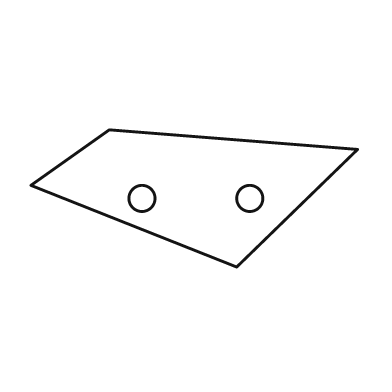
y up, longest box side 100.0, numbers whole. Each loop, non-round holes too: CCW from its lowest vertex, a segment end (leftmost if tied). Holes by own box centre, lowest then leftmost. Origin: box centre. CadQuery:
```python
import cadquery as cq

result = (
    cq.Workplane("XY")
    .moveTo(13.0, -21.0)
    .lineTo(50.0, 15.0)
    .lineTo(-26.0, 21.0)
    .lineTo(-50.0, 4.0)
    .close()
    .moveTo(-16.0, 0.0)
    .circle(4.0)
    .moveTo(17.0, 0.0)
    .circle(4.0)
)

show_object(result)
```